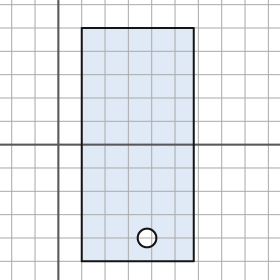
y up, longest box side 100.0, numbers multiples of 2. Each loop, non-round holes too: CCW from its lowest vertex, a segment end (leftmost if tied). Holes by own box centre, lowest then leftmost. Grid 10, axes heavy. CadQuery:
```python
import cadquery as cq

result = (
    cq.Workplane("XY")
    .moveTo(10.0, -50.0)
    .lineTo(58.0, -50.0)
    .lineTo(58.0, 50.0)
    .lineTo(10.0, 50.0)
    .close()
    .moveTo(38.0, -40.0)
    .circle(4.0)
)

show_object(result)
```